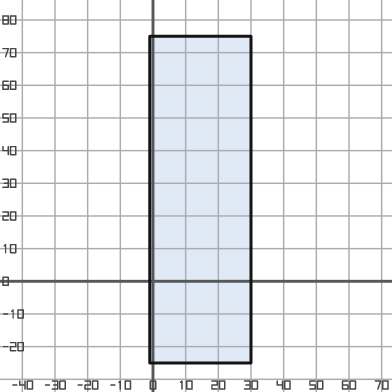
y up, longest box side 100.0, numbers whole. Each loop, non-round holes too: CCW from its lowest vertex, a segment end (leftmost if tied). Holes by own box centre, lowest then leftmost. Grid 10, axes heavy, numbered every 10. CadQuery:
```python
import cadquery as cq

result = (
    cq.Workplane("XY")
    .moveTo(-1.0, -25.0)
    .lineTo(30.0, -25.0)
    .lineTo(30.0, 75.0)
    .lineTo(-1.0, 75.0)
    .close()
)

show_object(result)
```